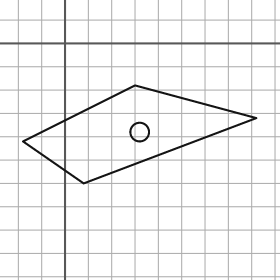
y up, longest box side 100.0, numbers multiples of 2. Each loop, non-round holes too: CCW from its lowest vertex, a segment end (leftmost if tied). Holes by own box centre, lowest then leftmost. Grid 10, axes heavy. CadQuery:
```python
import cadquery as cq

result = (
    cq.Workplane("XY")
    .moveTo(8.0, -60.0)
    .lineTo(82.0, -32.0)
    .lineTo(30.0, -18.0)
    .lineTo(-18.0, -42.0)
    .close()
    .moveTo(32.0, -38.0)
    .circle(4.0)
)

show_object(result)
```